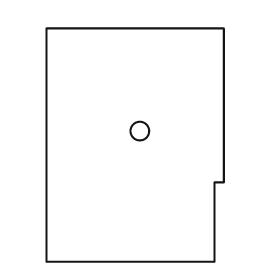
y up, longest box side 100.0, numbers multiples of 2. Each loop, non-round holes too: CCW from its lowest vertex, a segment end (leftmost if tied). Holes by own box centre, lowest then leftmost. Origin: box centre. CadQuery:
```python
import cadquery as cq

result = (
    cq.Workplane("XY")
    .moveTo(-38.0, -50.0)
    .lineTo(34.0, -50.0)
    .lineTo(34.0, -16.0)
    .lineTo(38.0, -16.0)
    .lineTo(38.0, 50.0)
    .lineTo(-38.0, 50.0)
    .close()
    .moveTo(2.0, 6.0)
    .circle(4.0)
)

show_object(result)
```